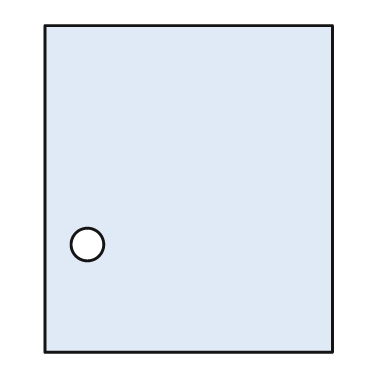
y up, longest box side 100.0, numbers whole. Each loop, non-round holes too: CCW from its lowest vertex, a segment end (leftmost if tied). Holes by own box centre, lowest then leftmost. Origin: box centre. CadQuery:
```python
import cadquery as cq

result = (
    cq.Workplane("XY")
    .moveTo(-44.0, -50.0)
    .lineTo(44.0, -50.0)
    .lineTo(44.0, 50.0)
    .lineTo(-44.0, 50.0)
    .close()
    .moveTo(-31.0, -17.0)
    .circle(5.0)
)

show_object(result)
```